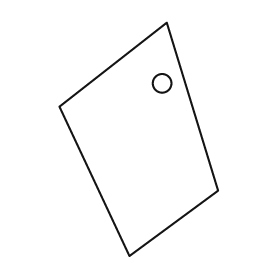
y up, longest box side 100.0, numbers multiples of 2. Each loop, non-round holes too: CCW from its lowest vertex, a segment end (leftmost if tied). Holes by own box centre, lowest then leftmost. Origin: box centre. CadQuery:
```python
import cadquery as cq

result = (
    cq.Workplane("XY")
    .moveTo(-4.0, -50.0)
    .lineTo(34.0, -22.0)
    .lineTo(12.0, 50.0)
    .lineTo(-34.0, 14.0)
    .close()
    .moveTo(10.0, 24.0)
    .circle(4.0)
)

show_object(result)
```